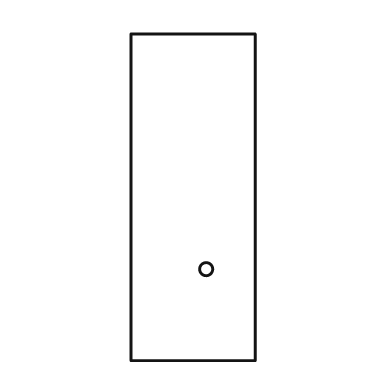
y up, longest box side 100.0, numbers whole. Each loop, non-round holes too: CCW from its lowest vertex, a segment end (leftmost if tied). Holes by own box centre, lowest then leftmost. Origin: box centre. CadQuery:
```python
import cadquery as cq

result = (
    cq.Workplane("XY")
    .moveTo(-19.0, -50.0)
    .lineTo(19.0, -50.0)
    .lineTo(19.0, 50.0)
    .lineTo(-19.0, 50.0)
    .close()
    .moveTo(4.0, -22.0)
    .circle(2.0)
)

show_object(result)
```